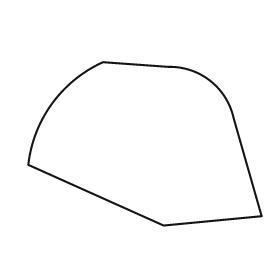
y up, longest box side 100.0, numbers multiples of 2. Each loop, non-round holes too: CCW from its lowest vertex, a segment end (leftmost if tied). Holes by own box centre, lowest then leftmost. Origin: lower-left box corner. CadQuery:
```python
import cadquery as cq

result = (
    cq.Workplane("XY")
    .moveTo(58.0, 0.0)
    .lineTo(100.0, 4.0)
    .lineTo(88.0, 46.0)
    .threePointArc((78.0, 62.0), (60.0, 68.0))
    .lineTo(32.0, 70.0)
    .threePointArc((10.0, 52.0), (0.0, 26.0))
    .close()
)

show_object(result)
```